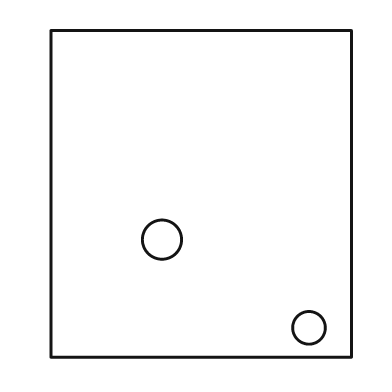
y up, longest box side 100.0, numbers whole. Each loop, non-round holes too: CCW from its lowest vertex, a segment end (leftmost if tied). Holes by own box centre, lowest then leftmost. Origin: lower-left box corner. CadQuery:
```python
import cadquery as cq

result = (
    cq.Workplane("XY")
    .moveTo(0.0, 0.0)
    .lineTo(92.0, 0.0)
    .lineTo(92.0, 100.0)
    .lineTo(0.0, 100.0)
    .close()
    .moveTo(79.0, 9.0)
    .circle(5.0)
    .moveTo(34.0, 36.0)
    .circle(6.0)
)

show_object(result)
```